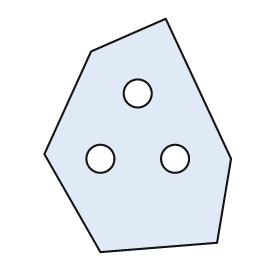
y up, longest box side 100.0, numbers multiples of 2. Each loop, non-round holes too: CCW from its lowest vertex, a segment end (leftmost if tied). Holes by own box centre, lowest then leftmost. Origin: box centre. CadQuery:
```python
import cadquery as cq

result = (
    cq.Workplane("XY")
    .moveTo(-16.0, -50.0)
    .lineTo(34.0, -46.0)
    .lineTo(40.0, -10.0)
    .lineTo(12.0, 50.0)
    .lineTo(-20.0, 36.0)
    .lineTo(-40.0, -8.0)
    .close()
    .moveTo(-16.0, -10.0)
    .circle(6.0)
    .moveTo(16.0, -10.0)
    .circle(6.0)
    .moveTo(0.0, 18.0)
    .circle(6.0)
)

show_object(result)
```